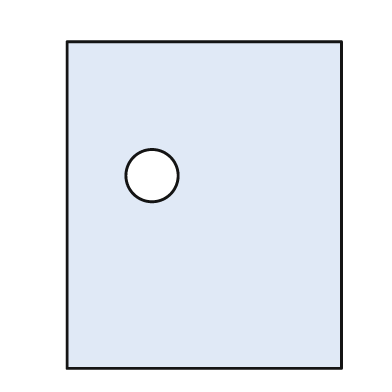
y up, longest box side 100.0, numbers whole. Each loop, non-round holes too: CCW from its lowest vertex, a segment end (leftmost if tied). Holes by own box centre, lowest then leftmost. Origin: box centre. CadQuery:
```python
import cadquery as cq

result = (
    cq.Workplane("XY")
    .moveTo(-42.0, -50.0)
    .lineTo(42.0, -50.0)
    .lineTo(42.0, 50.0)
    .lineTo(-42.0, 50.0)
    .close()
    .moveTo(-16.0, 9.0)
    .circle(8.0)
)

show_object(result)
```